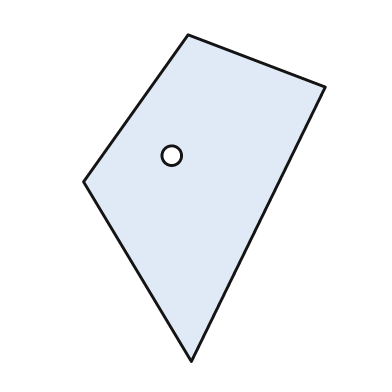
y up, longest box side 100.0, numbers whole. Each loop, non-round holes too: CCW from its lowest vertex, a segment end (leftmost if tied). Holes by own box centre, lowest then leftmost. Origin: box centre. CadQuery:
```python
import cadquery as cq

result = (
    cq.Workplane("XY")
    .moveTo(-4.0, -50.0)
    .lineTo(37.0, 34.0)
    .lineTo(-5.0, 50.0)
    .lineTo(-37.0, 5.0)
    .close()
    .moveTo(-10.0, 13.0)
    .circle(3.0)
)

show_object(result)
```